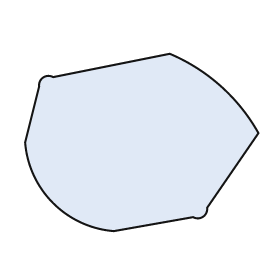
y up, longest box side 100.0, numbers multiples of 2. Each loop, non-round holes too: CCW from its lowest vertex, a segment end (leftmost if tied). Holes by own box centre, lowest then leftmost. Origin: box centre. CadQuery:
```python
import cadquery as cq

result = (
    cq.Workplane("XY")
    .moveTo(-12.0, -38.0)
    .lineTo(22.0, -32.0)
    .threePointArc((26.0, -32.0), (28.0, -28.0))
    .lineTo(50.0, 4.0)
    .threePointArc((34.0, 24.0), (12.0, 38.0))
    .lineTo(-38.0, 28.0)
    .threePointArc((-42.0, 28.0), (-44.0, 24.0))
    .lineTo(-50.0, 0.0)
    .threePointArc((-38.0, -26.0), (-12.0, -38.0))
    .close()
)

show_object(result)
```